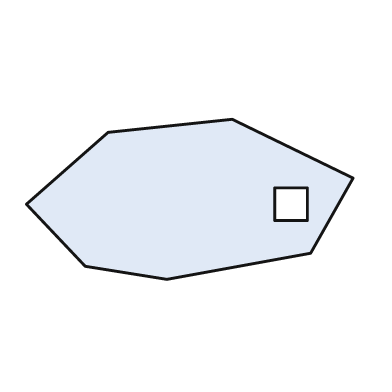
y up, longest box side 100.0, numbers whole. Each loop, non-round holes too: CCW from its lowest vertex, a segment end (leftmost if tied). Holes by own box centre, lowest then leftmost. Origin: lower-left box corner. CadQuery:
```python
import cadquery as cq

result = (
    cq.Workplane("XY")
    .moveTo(43.0, 0.0)
    .lineTo(87.0, 8.0)
    .lineTo(100.0, 31.0)
    .lineTo(63.0, 49.0)
    .lineTo(25.0, 45.0)
    .lineTo(0.0, 23.0)
    .lineTo(18.0, 4.0)
    .close()
    .moveTo(76.0, 18.0)
    .lineTo(86.0, 18.0)
    .lineTo(86.0, 28.0)
    .lineTo(76.0, 28.0)
    .close()
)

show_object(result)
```